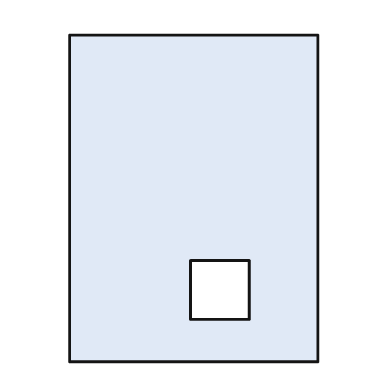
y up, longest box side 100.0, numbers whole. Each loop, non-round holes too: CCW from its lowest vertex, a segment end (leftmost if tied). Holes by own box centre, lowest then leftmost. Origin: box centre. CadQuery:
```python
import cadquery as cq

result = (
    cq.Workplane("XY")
    .moveTo(-38.0, -50.0)
    .lineTo(38.0, -50.0)
    .lineTo(38.0, 50.0)
    .lineTo(-38.0, 50.0)
    .close()
    .moveTo(-1.0, -37.0)
    .lineTo(17.0, -37.0)
    .lineTo(17.0, -19.0)
    .lineTo(-1.0, -19.0)
    .close()
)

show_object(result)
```